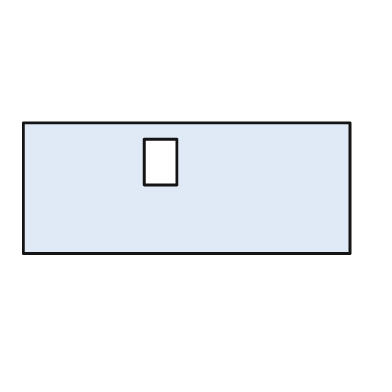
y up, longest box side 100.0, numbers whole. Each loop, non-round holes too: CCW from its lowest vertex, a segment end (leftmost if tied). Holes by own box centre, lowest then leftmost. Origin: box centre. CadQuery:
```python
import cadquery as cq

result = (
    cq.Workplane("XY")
    .moveTo(-50.0, -20.0)
    .lineTo(50.0, -20.0)
    .lineTo(50.0, 20.0)
    .lineTo(-50.0, 20.0)
    .close()
    .moveTo(-13.0, 1.0)
    .lineTo(-3.0, 1.0)
    .lineTo(-3.0, 15.0)
    .lineTo(-13.0, 15.0)
    .close()
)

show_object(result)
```